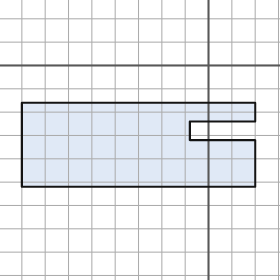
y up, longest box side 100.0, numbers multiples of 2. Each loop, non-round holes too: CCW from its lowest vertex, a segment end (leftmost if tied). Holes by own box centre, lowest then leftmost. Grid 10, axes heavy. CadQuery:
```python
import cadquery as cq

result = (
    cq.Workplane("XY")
    .moveTo(-80.0, -52.0)
    .lineTo(20.0, -52.0)
    .lineTo(20.0, -32.0)
    .lineTo(-8.0, -32.0)
    .lineTo(-8.0, -24.0)
    .lineTo(20.0, -24.0)
    .lineTo(20.0, -16.0)
    .lineTo(-80.0, -16.0)
    .close()
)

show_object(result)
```